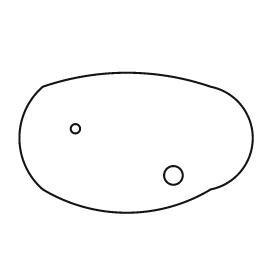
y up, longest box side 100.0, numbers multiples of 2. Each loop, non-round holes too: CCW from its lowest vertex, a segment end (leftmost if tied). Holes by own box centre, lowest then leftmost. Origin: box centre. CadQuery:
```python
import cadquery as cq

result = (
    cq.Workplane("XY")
    .moveTo(-40.0, -20.0)
    .threePointArc((-4.0, -30.0), (32.0, -20.0))
    .threePointArc((50.0, 2.0), (32.0, 24.0))
    .threePointArc((-4.0, 30.0), (-40.0, 24.0))
    .threePointArc((-50.0, 2.0), (-40.0, -20.0))
    .close()
    .moveTo(16.0, -14.0)
    .circle(4.0)
    .moveTo(-26.0, 6.0)
    .circle(2.0)
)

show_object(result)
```